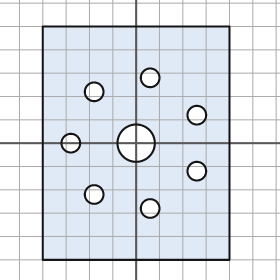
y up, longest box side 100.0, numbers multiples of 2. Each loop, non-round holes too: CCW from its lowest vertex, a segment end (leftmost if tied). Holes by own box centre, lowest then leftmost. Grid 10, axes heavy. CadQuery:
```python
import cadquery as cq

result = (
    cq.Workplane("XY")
    .moveTo(-40.0, -50.0)
    .lineTo(40.0, -50.0)
    .lineTo(40.0, 50.0)
    .lineTo(-40.0, 50.0)
    .close()
    .moveTo(6.0, -28.0)
    .circle(4.0)
    .moveTo(-18.0, -22.0)
    .circle(4.0)
    .moveTo(26.0, -12.0)
    .circle(4.0)
    .moveTo(-28.0, 0.0)
    .circle(4.0)
    .moveTo(0.0, 0.0)
    .circle(8.0)
    .moveTo(26.0, 12.0)
    .circle(4.0)
    .moveTo(-18.0, 22.0)
    .circle(4.0)
    .moveTo(6.0, 28.0)
    .circle(4.0)
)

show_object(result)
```